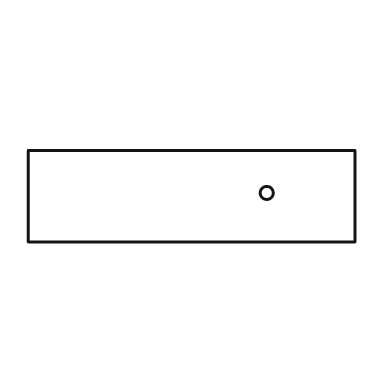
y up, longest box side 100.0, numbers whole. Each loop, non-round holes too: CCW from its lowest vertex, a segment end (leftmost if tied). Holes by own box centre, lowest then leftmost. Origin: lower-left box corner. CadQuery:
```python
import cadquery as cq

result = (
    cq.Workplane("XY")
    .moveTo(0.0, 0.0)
    .lineTo(100.0, 0.0)
    .lineTo(100.0, 28.0)
    .lineTo(0.0, 28.0)
    .close()
    .moveTo(73.0, 15.0)
    .circle(2.0)
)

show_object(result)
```